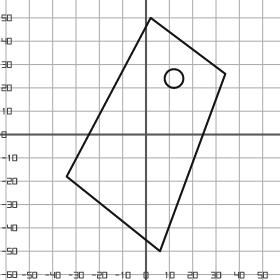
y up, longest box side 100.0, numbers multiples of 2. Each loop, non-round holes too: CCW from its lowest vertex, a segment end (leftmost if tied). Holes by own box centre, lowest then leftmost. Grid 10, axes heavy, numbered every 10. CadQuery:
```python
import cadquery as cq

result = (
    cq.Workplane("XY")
    .moveTo(6.0, -50.0)
    .lineTo(34.0, 26.0)
    .lineTo(2.0, 50.0)
    .lineTo(-34.0, -18.0)
    .close()
    .moveTo(12.0, 24.0)
    .circle(4.0)
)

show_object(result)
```